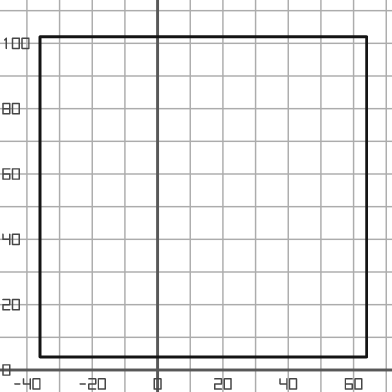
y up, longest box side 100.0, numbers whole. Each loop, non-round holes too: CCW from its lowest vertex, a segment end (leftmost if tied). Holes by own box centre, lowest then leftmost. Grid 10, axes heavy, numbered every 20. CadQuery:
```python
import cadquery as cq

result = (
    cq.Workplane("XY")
    .moveTo(-36.0, 4.0)
    .lineTo(64.0, 4.0)
    .lineTo(64.0, 102.0)
    .lineTo(-36.0, 102.0)
    .close()
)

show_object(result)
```